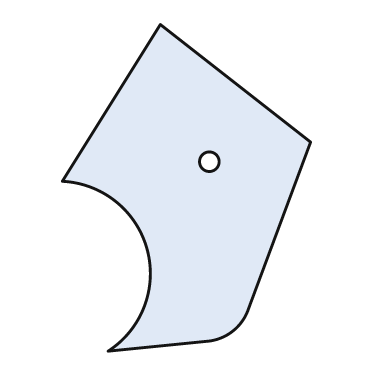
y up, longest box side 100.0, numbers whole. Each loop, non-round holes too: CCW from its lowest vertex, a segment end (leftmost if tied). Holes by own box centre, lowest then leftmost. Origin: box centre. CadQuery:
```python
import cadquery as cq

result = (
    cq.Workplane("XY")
    .moveTo(-24.0, -50.0)
    .lineTo(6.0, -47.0)
    .threePointArc((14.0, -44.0), (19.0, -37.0))
    .lineTo(38.0, 14.0)
    .lineTo(-8.0, 50.0)
    .lineTo(-38.0, 2.0)
    .threePointArc((-12.0, -19.0), (-24.0, -50.0))
    .close()
    .moveTo(7.0, 8.0)
    .circle(3.0)
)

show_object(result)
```